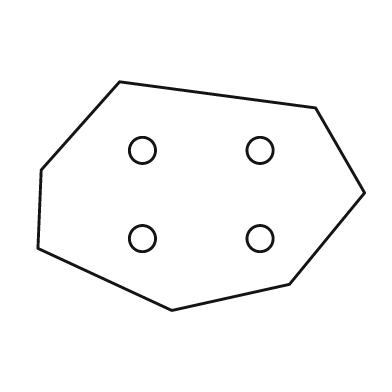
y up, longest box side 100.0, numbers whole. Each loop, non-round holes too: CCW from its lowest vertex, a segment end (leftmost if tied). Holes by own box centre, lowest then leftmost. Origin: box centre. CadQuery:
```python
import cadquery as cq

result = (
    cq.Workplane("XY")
    .moveTo(-9.0, -35.0)
    .lineTo(27.0, -27.0)
    .lineTo(50.0, 1.0)
    .lineTo(35.0, 27.0)
    .lineTo(-25.0, 35.0)
    .lineTo(-49.0, 8.0)
    .lineTo(-50.0, -16.0)
    .close()
    .moveTo(-18.0, -13.0)
    .circle(4.0)
    .moveTo(18.0, -13.0)
    .circle(4.0)
    .moveTo(-18.0, 14.0)
    .circle(4.0)
    .moveTo(18.0, 14.0)
    .circle(4.0)
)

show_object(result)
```